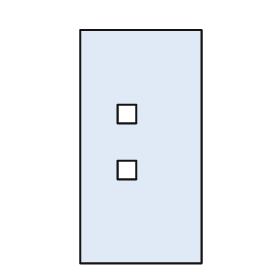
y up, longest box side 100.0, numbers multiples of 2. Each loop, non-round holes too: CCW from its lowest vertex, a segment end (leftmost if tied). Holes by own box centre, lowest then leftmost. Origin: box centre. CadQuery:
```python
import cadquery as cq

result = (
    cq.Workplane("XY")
    .moveTo(-26.0, -50.0)
    .lineTo(26.0, -50.0)
    .lineTo(26.0, 50.0)
    .lineTo(-26.0, 50.0)
    .close()
    .moveTo(-10.0, -14.0)
    .lineTo(-2.0, -14.0)
    .lineTo(-2.0, -6.0)
    .lineTo(-10.0, -6.0)
    .close()
    .moveTo(-10.0, 10.0)
    .lineTo(-2.0, 10.0)
    .lineTo(-2.0, 18.0)
    .lineTo(-10.0, 18.0)
    .close()
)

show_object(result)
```